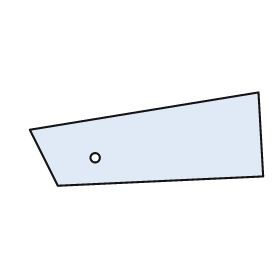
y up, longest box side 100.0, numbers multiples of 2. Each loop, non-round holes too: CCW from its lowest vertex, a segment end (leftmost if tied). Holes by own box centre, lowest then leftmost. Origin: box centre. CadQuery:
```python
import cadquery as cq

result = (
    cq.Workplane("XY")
    .moveTo(-38.0, -20.0)
    .lineTo(50.0, -16.0)
    .lineTo(48.0, 20.0)
    .lineTo(-50.0, 4.0)
    .close()
    .moveTo(-22.0, -8.0)
    .circle(2.0)
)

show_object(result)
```